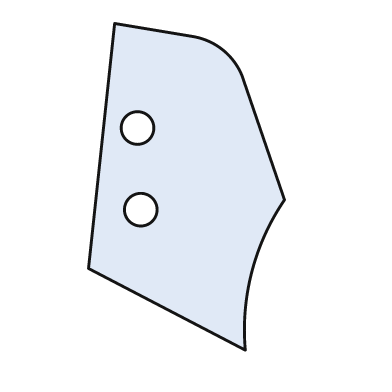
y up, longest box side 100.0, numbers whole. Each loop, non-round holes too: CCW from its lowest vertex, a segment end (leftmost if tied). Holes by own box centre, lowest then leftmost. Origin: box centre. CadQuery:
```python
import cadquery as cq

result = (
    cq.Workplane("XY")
    .moveTo(18.0, -50.0)
    .threePointArc((20.0, -26.0), (30.0, -4.0))
    .lineTo(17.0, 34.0)
    .threePointArc((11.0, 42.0), (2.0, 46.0))
    .lineTo(-22.0, 50.0)
    .lineTo(-30.0, -25.0)
    .close()
    .moveTo(-14.0, -7.0)
    .circle(5.0)
    .moveTo(-15.0, 18.0)
    .circle(5.0)
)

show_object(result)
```